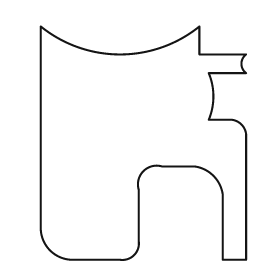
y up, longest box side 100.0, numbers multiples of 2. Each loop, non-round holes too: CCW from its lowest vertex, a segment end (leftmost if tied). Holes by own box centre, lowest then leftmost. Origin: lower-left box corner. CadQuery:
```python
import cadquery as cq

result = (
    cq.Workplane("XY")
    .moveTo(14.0, 0.0)
    .lineTo(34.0, 0.0)
    .threePointArc((40.0, 2.0), (42.0, 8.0))
    .lineTo(42.0, 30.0)
    .threePointArc((44.0, 38.0), (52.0, 40.0))
    .lineTo(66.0, 40.0)
    .threePointArc((74.0, 36.0), (78.0, 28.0))
    .lineTo(78.0, 0.0)
    .lineTo(88.0, 0.0)
    .lineTo(88.0, 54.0)
    .threePointArc((86.0, 58.0), (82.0, 60.0))
    .lineTo(72.0, 60.0)
    .threePointArc((74.0, 70.0), (72.0, 80.0))
    .lineTo(88.0, 80.0)
    .threePointArc((86.0, 84.0), (88.0, 88.0))
    .lineTo(68.0, 88.0)
    .lineTo(68.0, 100.0)
    .threePointArc((34.0, 88.0), (0.0, 100.0))
    .lineTo(0.0, 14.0)
    .threePointArc((4.0, 4.0), (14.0, 0.0))
    .close()
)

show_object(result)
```